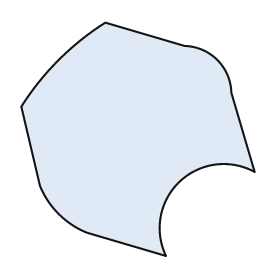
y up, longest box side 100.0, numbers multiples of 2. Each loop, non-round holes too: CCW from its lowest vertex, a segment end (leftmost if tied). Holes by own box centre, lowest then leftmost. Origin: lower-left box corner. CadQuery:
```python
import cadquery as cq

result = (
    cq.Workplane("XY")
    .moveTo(62.0, 0.0)
    .threePointArc((68.0, 32.0), (100.0, 36.0))
    .lineTo(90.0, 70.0)
    .threePointArc((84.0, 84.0), (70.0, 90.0))
    .lineTo(36.0, 100.0)
    .threePointArc((16.0, 84.0), (0.0, 64.0))
    .lineTo(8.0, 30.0)
    .threePointArc((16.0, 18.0), (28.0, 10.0))
    .close()
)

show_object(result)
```